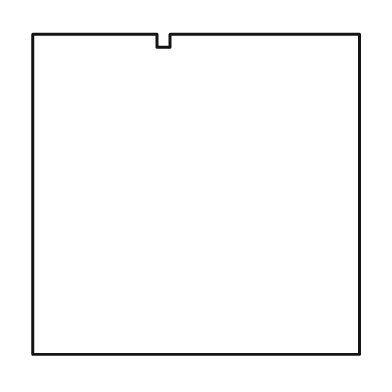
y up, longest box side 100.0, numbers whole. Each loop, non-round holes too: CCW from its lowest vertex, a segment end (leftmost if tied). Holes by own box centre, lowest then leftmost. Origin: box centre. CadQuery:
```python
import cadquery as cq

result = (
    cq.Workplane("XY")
    .moveTo(-50.0, -49.0)
    .lineTo(50.0, -49.0)
    .lineTo(50.0, 49.0)
    .lineTo(-8.0, 49.0)
    .lineTo(-8.0, 45.0)
    .lineTo(-12.0, 45.0)
    .lineTo(-12.0, 49.0)
    .lineTo(-50.0, 49.0)
    .close()
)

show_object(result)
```